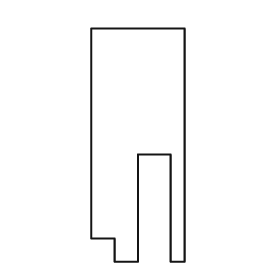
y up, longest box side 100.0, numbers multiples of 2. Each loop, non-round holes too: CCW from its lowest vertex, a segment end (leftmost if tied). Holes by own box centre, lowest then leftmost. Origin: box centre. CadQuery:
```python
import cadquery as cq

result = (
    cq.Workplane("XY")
    .moveTo(-10.0, -50.0)
    .lineTo(0.0, -50.0)
    .lineTo(0.0, -4.0)
    .lineTo(14.0, -4.0)
    .lineTo(14.0, -50.0)
    .lineTo(20.0, -50.0)
    .lineTo(20.0, 50.0)
    .lineTo(-20.0, 50.0)
    .lineTo(-20.0, -40.0)
    .lineTo(-10.0, -40.0)
    .close()
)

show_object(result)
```